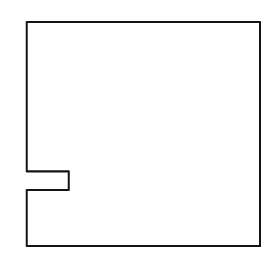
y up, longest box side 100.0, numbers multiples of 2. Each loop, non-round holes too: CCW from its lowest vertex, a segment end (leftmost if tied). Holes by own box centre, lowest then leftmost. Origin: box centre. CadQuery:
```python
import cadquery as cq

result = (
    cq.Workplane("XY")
    .moveTo(-50.0, -48.0)
    .lineTo(50.0, -48.0)
    .lineTo(50.0, 48.0)
    .lineTo(-50.0, 48.0)
    .lineTo(-50.0, -16.0)
    .lineTo(-32.0, -16.0)
    .lineTo(-32.0, -24.0)
    .lineTo(-50.0, -24.0)
    .close()
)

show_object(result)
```